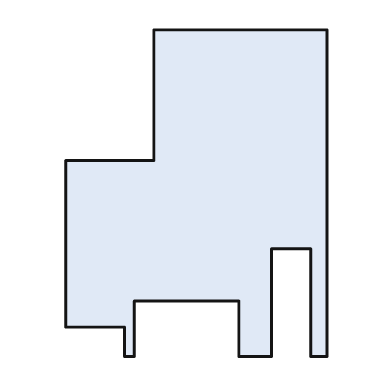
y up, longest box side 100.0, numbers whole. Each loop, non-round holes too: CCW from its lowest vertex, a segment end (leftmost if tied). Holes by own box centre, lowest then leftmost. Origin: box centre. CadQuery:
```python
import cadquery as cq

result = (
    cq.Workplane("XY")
    .moveTo(-22.0, -50.0)
    .lineTo(-19.0, -50.0)
    .lineTo(-19.0, -33.0)
    .lineTo(13.0, -33.0)
    .lineTo(13.0, -50.0)
    .lineTo(23.0, -50.0)
    .lineTo(23.0, -17.0)
    .lineTo(35.0, -17.0)
    .lineTo(35.0, -50.0)
    .lineTo(40.0, -50.0)
    .lineTo(40.0, 50.0)
    .lineTo(-13.0, 50.0)
    .lineTo(-13.0, 10.0)
    .lineTo(-40.0, 10.0)
    .lineTo(-40.0, -41.0)
    .lineTo(-22.0, -41.0)
    .close()
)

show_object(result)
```